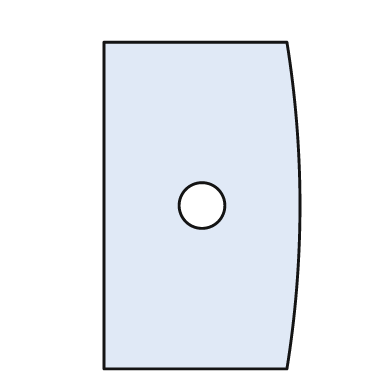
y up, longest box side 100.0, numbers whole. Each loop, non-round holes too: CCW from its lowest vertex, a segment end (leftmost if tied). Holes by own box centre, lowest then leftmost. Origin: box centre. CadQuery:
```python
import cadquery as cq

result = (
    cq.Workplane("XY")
    .moveTo(-30.0, -50.0)
    .lineTo(26.0, -50.0)
    .threePointArc((30.0, 0.0), (26.0, 50.0))
    .lineTo(-30.0, 50.0)
    .close()
    .moveTo(0.0, 0.0)
    .circle(7.0)
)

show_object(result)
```